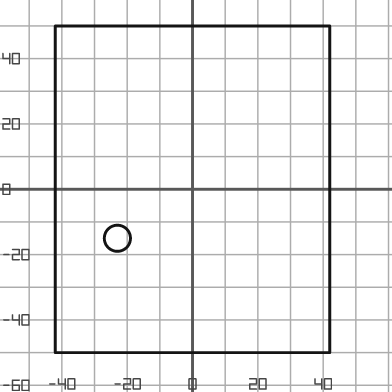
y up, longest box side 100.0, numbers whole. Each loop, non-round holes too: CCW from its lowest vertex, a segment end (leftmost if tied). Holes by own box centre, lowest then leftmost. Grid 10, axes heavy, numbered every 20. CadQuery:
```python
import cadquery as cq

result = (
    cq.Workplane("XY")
    .moveTo(-42.0, -50.0)
    .lineTo(42.0, -50.0)
    .lineTo(42.0, 50.0)
    .lineTo(-42.0, 50.0)
    .close()
    .moveTo(-23.0, -15.0)
    .circle(4.0)
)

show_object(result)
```